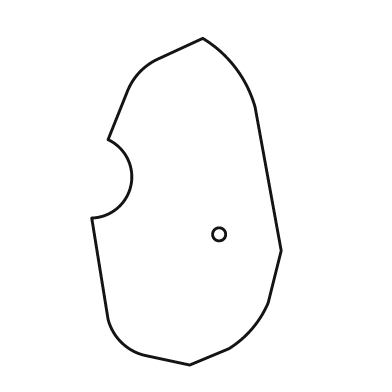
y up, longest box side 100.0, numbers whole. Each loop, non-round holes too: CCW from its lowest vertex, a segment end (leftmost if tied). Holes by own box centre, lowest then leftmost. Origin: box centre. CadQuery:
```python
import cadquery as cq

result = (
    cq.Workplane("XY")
    .moveTo(1.0, -50.0)
    .lineTo(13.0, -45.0)
    .threePointArc((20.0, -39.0), (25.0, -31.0))
    .lineTo(29.0, -15.0)
    .lineTo(21.0, 29.0)
    .threePointArc((15.0, 41.0), (5.0, 50.0))
    .lineTo(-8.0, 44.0)
    .threePointArc((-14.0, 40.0), (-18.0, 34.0))
    .lineTo(-24.0, 19.0)
    .threePointArc((-17.0, 5.0), (-29.0, -5.0))
    .lineTo(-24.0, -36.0)
    .threePointArc((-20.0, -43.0), (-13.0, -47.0))
    .close()
    .moveTo(10.0, -10.0)
    .circle(2.0)
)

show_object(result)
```